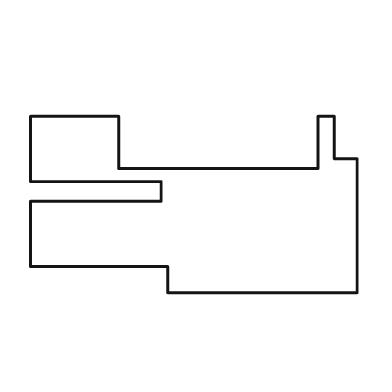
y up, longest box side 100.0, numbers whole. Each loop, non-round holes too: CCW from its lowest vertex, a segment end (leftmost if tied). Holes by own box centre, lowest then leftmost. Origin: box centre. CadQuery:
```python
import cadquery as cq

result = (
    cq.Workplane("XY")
    .moveTo(-8.0, -27.0)
    .lineTo(50.0, -27.0)
    .lineTo(50.0, 14.0)
    .lineTo(43.0, 14.0)
    .lineTo(43.0, 27.0)
    .lineTo(38.0, 27.0)
    .lineTo(38.0, 11.0)
    .lineTo(-23.0, 11.0)
    .lineTo(-23.0, 27.0)
    .lineTo(-50.0, 27.0)
    .lineTo(-50.0, 7.0)
    .lineTo(-10.0, 7.0)
    .lineTo(-10.0, 1.0)
    .lineTo(-50.0, 1.0)
    .lineTo(-50.0, -19.0)
    .lineTo(-8.0, -19.0)
    .close()
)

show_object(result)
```